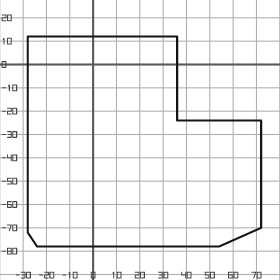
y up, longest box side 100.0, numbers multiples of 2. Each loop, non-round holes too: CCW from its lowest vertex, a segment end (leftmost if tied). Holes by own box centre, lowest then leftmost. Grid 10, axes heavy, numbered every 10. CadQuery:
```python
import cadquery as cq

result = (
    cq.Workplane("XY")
    .moveTo(-24.0, -78.0)
    .lineTo(54.0, -78.0)
    .lineTo(72.0, -70.0)
    .lineTo(72.0, -24.0)
    .lineTo(36.0, -24.0)
    .lineTo(36.0, 12.0)
    .lineTo(-28.0, 12.0)
    .lineTo(-28.0, -72.0)
    .close()
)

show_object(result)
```